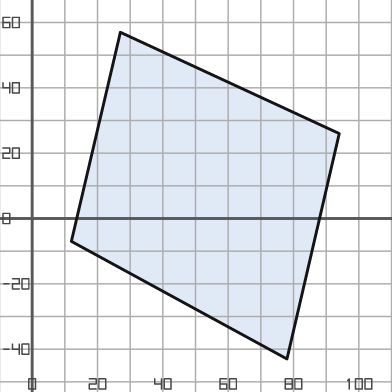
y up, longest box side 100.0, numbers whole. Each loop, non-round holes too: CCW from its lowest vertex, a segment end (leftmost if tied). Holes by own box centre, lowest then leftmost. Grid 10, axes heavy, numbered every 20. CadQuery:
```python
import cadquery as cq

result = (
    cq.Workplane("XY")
    .moveTo(78.0, -43.0)
    .lineTo(94.0, 26.0)
    .lineTo(27.0, 57.0)
    .lineTo(12.0, -7.0)
    .close()
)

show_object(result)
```